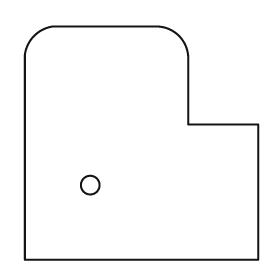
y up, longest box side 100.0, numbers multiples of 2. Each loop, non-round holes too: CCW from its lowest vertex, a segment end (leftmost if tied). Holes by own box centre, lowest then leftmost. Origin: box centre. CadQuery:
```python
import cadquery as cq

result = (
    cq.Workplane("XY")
    .moveTo(-50.0, -50.0)
    .lineTo(50.0, -50.0)
    .lineTo(50.0, 8.0)
    .lineTo(20.0, 8.0)
    .lineTo(20.0, 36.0)
    .threePointArc((16.0, 46.0), (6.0, 50.0))
    .lineTo(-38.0, 50.0)
    .threePointArc((-46.0, 46.0), (-50.0, 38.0))
    .close()
    .moveTo(-22.0, -18.0)
    .circle(4.0)
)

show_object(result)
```